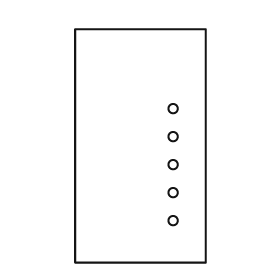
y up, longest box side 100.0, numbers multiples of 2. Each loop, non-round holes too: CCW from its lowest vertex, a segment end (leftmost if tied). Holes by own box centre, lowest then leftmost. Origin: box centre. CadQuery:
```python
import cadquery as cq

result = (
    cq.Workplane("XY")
    .moveTo(-28.0, -50.0)
    .lineTo(28.0, -50.0)
    .lineTo(28.0, 50.0)
    .lineTo(-28.0, 50.0)
    .close()
    .moveTo(14.0, -32.0)
    .circle(2.0)
    .moveTo(14.0, -20.0)
    .circle(2.0)
    .moveTo(14.0, -8.0)
    .circle(2.0)
    .moveTo(14.0, 4.0)
    .circle(2.0)
    .moveTo(14.0, 16.0)
    .circle(2.0)
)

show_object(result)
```